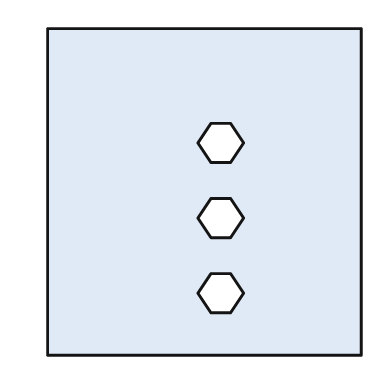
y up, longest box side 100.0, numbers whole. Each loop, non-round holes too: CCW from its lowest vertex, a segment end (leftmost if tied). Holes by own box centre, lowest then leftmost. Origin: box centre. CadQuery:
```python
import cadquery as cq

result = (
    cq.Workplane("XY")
    .moveTo(-48.0, -50.0)
    .lineTo(48.0, -50.0)
    .lineTo(48.0, 50.0)
    .lineTo(-48.0, 50.0)
    .close()
    .moveTo(2.0, -37.0)
    .lineTo(8.0, -37.0)
    .lineTo(12.0, -31.0)
    .lineTo(8.0, -25.0)
    .lineTo(2.0, -25.0)
    .lineTo(-2.0, -31.0)
    .close()
    .moveTo(2.0, -14.0)
    .lineTo(8.0, -14.0)
    .lineTo(12.0, -8.0)
    .lineTo(8.0, -2.0)
    .lineTo(2.0, -2.0)
    .lineTo(-2.0, -8.0)
    .close()
    .moveTo(2.0, 9.0)
    .lineTo(8.0, 9.0)
    .lineTo(12.0, 15.0)
    .lineTo(8.0, 21.0)
    .lineTo(2.0, 21.0)
    .lineTo(-2.0, 15.0)
    .close()
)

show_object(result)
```